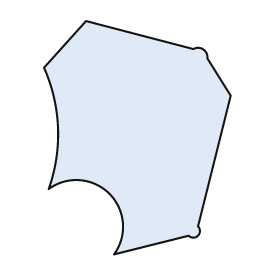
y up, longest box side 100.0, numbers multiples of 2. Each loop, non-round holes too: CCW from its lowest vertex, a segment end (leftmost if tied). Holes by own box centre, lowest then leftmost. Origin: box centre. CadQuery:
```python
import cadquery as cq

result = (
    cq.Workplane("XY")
    .moveTo(-10.0, -50.0)
    .lineTo(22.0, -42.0)
    .threePointArc((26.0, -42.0), (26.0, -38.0))
    .lineTo(40.0, 18.0)
    .lineTo(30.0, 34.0)
    .threePointArc((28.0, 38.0), (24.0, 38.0))
    .lineTo(-22.0, 50.0)
    .lineTo(-40.0, 30.0)
    .threePointArc((-34.0, 4.0), (-38.0, -22.0))
    .threePointArc((-12.0, -24.0), (-10.0, -50.0))
    .close()
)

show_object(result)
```